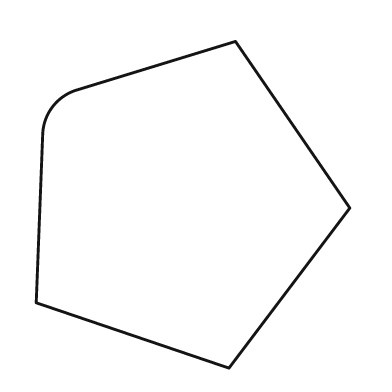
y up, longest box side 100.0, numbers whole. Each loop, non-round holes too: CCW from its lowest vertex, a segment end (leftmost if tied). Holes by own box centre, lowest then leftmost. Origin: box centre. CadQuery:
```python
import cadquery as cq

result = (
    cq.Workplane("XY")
    .moveTo(11.0, -50.0)
    .lineTo(48.0, -1.0)
    .lineTo(13.0, 50.0)
    .lineTo(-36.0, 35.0)
    .threePointArc((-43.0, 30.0), (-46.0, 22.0))
    .lineTo(-48.0, -30.0)
    .close()
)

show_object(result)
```